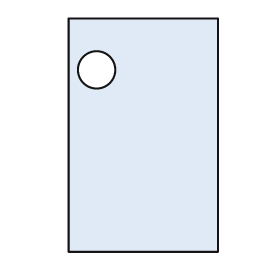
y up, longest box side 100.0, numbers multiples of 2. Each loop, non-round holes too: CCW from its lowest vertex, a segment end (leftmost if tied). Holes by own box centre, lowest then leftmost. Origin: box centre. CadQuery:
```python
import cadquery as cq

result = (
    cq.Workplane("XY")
    .moveTo(-32.0, -50.0)
    .lineTo(32.0, -50.0)
    .lineTo(32.0, 50.0)
    .lineTo(-32.0, 50.0)
    .close()
    .moveTo(-20.0, 28.0)
    .circle(8.0)
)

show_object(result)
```